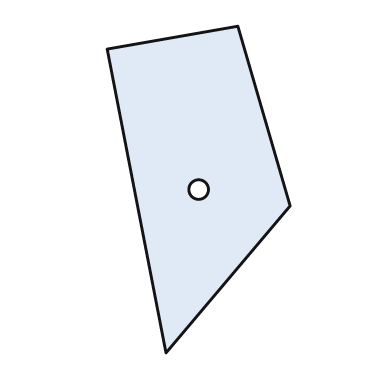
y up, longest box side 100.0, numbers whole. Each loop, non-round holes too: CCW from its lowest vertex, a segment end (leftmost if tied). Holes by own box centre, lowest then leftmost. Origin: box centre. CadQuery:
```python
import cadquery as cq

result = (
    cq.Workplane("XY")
    .moveTo(-10.0, -50.0)
    .lineTo(28.0, -5.0)
    .lineTo(12.0, 50.0)
    .lineTo(-28.0, 43.0)
    .close()
    .moveTo(0.0, 0.0)
    .circle(3.0)
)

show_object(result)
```